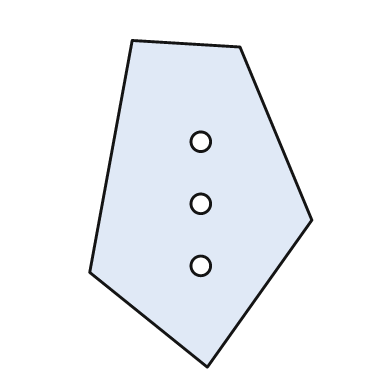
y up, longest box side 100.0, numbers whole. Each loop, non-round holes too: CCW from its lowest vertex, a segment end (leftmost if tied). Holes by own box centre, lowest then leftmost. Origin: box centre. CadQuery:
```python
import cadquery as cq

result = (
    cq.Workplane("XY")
    .moveTo(2.0, -50.0)
    .lineTo(34.0, -5.0)
    .lineTo(12.0, 48.0)
    .lineTo(-21.0, 50.0)
    .lineTo(-34.0, -21.0)
    .close()
    .moveTo(0.0, -19.0)
    .circle(3.0)
    .moveTo(0.0, 0.0)
    .circle(3.0)
    .moveTo(0.0, 19.0)
    .circle(3.0)
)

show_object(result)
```